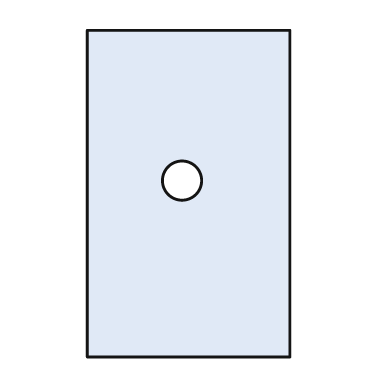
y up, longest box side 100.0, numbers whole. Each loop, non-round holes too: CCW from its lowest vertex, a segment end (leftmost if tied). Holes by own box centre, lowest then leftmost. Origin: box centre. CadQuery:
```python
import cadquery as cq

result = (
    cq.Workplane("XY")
    .moveTo(-31.0, -50.0)
    .lineTo(31.0, -50.0)
    .lineTo(31.0, 50.0)
    .lineTo(-31.0, 50.0)
    .close()
    .moveTo(-2.0, 4.0)
    .circle(6.0)
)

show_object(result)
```